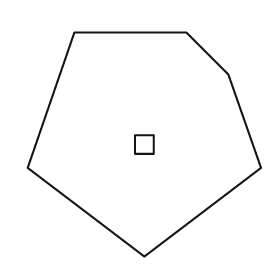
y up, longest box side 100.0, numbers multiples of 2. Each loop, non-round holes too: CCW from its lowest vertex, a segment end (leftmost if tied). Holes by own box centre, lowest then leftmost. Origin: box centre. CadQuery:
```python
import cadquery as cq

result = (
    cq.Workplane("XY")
    .moveTo(0.0, -48.0)
    .lineTo(50.0, -10.0)
    .lineTo(36.0, 30.0)
    .lineTo(18.0, 48.0)
    .lineTo(-30.0, 48.0)
    .lineTo(-50.0, -10.0)
    .close()
    .moveTo(-4.0, -4.0)
    .lineTo(4.0, -4.0)
    .lineTo(4.0, 4.0)
    .lineTo(-4.0, 4.0)
    .close()
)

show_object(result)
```